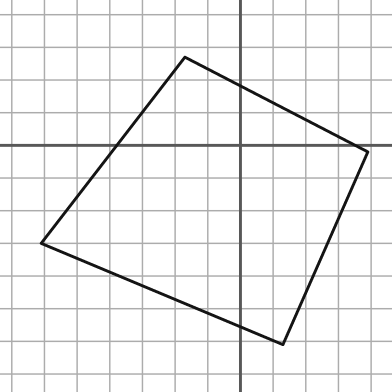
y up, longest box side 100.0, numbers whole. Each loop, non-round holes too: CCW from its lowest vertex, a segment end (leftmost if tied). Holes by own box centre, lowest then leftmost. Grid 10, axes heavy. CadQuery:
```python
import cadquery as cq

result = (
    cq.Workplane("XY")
    .moveTo(13.0, -61.0)
    .lineTo(39.0, -2.0)
    .lineTo(-17.0, 27.0)
    .lineTo(-61.0, -30.0)
    .close()
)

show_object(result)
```